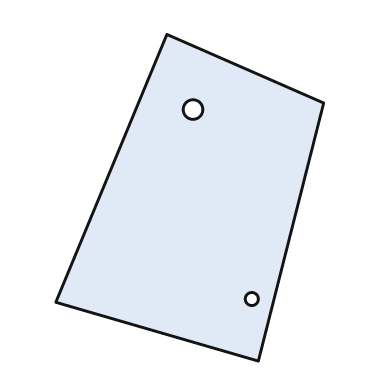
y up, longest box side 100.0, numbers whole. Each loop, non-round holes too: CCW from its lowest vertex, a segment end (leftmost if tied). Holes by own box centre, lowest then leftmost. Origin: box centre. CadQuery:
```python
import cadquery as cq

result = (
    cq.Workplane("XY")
    .moveTo(21.0, -50.0)
    .lineTo(41.0, 29.0)
    .lineTo(-7.0, 50.0)
    .lineTo(-41.0, -32.0)
    .close()
    .moveTo(19.0, -31.0)
    .circle(2.0)
    .moveTo(1.0, 27.0)
    .circle(3.0)
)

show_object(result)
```